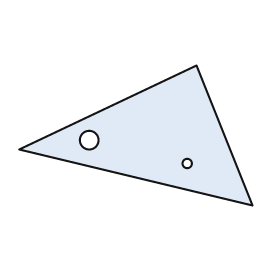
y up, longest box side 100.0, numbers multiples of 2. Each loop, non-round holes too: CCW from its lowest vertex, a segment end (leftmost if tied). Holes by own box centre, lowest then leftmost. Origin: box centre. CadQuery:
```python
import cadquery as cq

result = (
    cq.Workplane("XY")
    .moveTo(50.0, -30.0)
    .lineTo(26.0, 30.0)
    .lineTo(-50.0, -6.0)
    .close()
    .moveTo(22.0, -12.0)
    .circle(2.0)
    .moveTo(-20.0, -2.0)
    .circle(4.0)
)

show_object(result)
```